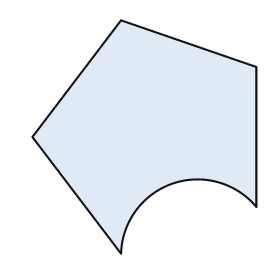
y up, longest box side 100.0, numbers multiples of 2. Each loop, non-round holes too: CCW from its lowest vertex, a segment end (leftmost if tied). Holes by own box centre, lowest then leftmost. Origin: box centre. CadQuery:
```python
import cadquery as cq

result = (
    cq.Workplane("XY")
    .moveTo(-10.0, -50.0)
    .threePointArc((12.0, -20.0), (48.0, -30.0))
    .lineTo(48.0, 30.0)
    .lineTo(-10.0, 50.0)
    .lineTo(-48.0, 0.0)
    .close()
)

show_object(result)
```